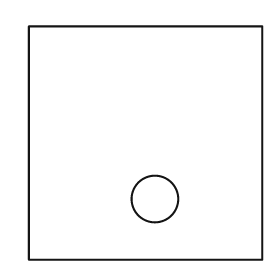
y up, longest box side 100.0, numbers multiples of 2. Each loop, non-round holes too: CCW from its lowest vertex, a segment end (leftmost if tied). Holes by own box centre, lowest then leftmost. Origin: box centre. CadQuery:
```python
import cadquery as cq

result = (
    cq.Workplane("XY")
    .moveTo(-50.0, -50.0)
    .lineTo(50.0, -50.0)
    .lineTo(50.0, 50.0)
    .lineTo(-50.0, 50.0)
    .close()
    .moveTo(4.0, -24.0)
    .circle(10.0)
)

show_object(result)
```